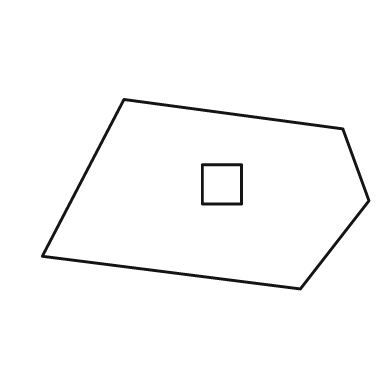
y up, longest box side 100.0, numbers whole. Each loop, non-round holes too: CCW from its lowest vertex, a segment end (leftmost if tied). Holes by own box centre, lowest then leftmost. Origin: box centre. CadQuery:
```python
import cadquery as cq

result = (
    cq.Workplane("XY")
    .moveTo(29.0, -29.0)
    .lineTo(50.0, -2.0)
    .lineTo(42.0, 20.0)
    .lineTo(-25.0, 29.0)
    .lineTo(-50.0, -19.0)
    .close()
    .moveTo(-1.0, -3.0)
    .lineTo(11.0, -3.0)
    .lineTo(11.0, 9.0)
    .lineTo(-1.0, 9.0)
    .close()
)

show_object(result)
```